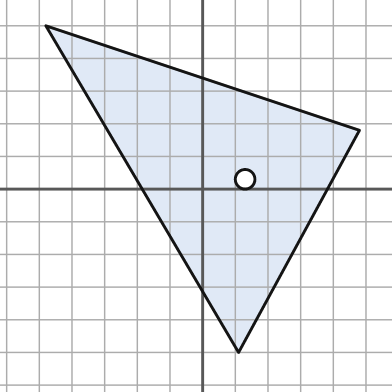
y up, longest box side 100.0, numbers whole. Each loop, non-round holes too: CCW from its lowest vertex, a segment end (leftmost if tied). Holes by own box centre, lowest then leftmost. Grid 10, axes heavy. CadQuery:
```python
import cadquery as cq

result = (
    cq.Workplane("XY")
    .moveTo(11.0, -50.0)
    .lineTo(48.0, 18.0)
    .lineTo(-48.0, 50.0)
    .close()
    .moveTo(13.0, 3.0)
    .circle(3.0)
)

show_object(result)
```